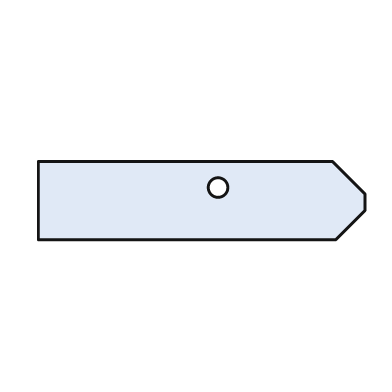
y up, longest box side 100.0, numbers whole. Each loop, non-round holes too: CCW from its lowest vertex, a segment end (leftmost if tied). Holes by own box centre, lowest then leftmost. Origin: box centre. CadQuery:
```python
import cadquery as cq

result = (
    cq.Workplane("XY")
    .moveTo(-50.0, -12.0)
    .lineTo(41.0, -12.0)
    .lineTo(50.0, -3.0)
    .lineTo(50.0, 2.0)
    .lineTo(40.0, 12.0)
    .lineTo(-50.0, 12.0)
    .close()
    .moveTo(5.0, 4.0)
    .circle(3.0)
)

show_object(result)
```